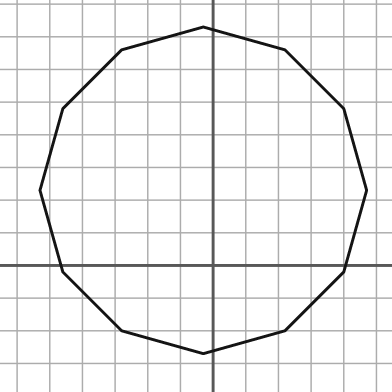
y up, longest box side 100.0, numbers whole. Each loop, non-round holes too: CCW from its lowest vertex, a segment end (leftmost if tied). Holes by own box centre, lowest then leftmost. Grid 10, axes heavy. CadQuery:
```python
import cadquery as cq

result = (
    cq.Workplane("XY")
    .moveTo(-3.0, -27.0)
    .lineTo(22.0, -20.0)
    .lineTo(40.0, -2.0)
    .lineTo(47.0, 23.0)
    .lineTo(40.0, 48.0)
    .lineTo(22.0, 66.0)
    .lineTo(-3.0, 73.0)
    .lineTo(-28.0, 66.0)
    .lineTo(-46.0, 48.0)
    .lineTo(-53.0, 23.0)
    .lineTo(-46.0, -2.0)
    .lineTo(-28.0, -20.0)
    .close()
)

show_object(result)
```